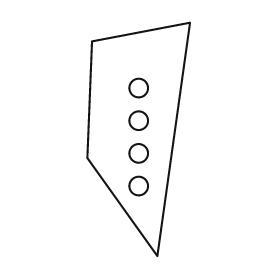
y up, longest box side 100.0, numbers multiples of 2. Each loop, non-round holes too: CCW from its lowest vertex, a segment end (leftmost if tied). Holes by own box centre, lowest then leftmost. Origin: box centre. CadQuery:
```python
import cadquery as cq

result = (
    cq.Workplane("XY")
    .moveTo(8.0, -50.0)
    .lineTo(22.0, 50.0)
    .lineTo(-20.0, 42.0)
    .lineTo(-22.0, -8.0)
    .close()
    .moveTo(0.0, -20.0)
    .circle(4.0)
    .moveTo(0.0, -6.0)
    .circle(4.0)
    .moveTo(0.0, 8.0)
    .circle(4.0)
    .moveTo(0.0, 22.0)
    .circle(4.0)
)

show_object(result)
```